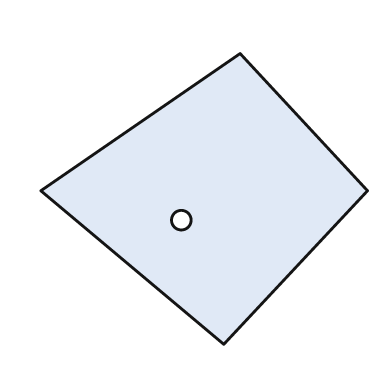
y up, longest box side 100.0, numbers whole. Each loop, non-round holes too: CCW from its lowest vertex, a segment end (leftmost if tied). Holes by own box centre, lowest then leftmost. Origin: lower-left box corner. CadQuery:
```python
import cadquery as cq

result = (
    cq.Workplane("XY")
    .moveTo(56.0, 0.0)
    .lineTo(100.0, 47.0)
    .lineTo(61.0, 89.0)
    .lineTo(0.0, 47.0)
    .close()
    .moveTo(43.0, 38.0)
    .circle(3.0)
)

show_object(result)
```